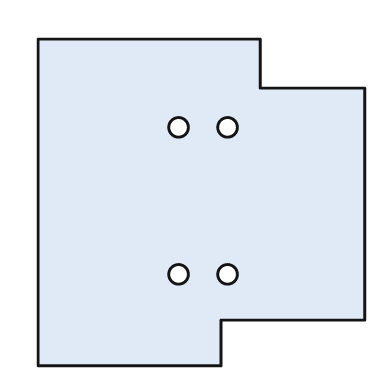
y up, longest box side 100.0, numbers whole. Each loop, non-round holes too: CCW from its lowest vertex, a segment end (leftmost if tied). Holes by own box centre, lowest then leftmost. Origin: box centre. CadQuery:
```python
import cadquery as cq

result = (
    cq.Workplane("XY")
    .moveTo(-50.0, -50.0)
    .lineTo(6.0, -50.0)
    .lineTo(6.0, -36.0)
    .lineTo(50.0, -36.0)
    .lineTo(50.0, 35.0)
    .lineTo(18.0, 35.0)
    .lineTo(18.0, 50.0)
    .lineTo(-50.0, 50.0)
    .close()
    .moveTo(-7.0, -22.0)
    .circle(3.0)
    .moveTo(8.0, -22.0)
    .circle(3.0)
    .moveTo(-7.0, 23.0)
    .circle(3.0)
    .moveTo(8.0, 23.0)
    .circle(3.0)
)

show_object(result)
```